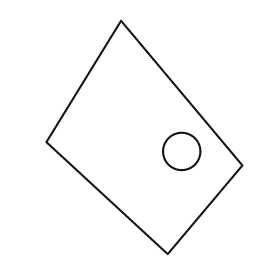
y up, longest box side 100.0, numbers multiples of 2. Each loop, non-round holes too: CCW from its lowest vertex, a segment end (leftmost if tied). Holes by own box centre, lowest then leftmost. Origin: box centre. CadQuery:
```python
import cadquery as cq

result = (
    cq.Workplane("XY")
    .moveTo(10.0, -50.0)
    .lineTo(42.0, -12.0)
    .lineTo(-10.0, 50.0)
    .lineTo(-42.0, -2.0)
    .close()
    .moveTo(16.0, -6.0)
    .circle(8.0)
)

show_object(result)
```